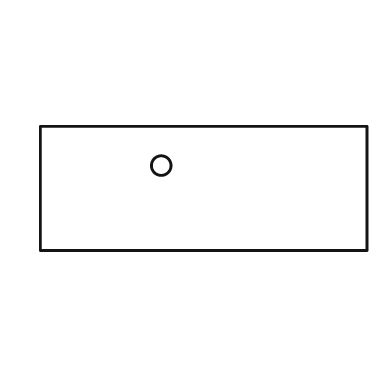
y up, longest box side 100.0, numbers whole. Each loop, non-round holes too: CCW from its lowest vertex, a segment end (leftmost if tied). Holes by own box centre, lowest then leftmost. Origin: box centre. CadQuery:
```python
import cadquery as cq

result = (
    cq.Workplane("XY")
    .moveTo(-50.0, -19.0)
    .lineTo(50.0, -19.0)
    .lineTo(50.0, 19.0)
    .lineTo(-50.0, 19.0)
    .close()
    .moveTo(-13.0, 7.0)
    .circle(3.0)
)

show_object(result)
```